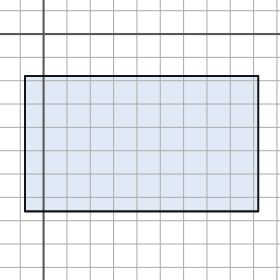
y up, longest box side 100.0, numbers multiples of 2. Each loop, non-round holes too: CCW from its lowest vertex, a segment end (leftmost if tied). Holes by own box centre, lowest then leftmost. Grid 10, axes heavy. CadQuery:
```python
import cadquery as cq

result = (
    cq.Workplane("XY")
    .moveTo(-8.0, -76.0)
    .lineTo(92.0, -76.0)
    .lineTo(92.0, -18.0)
    .lineTo(-8.0, -18.0)
    .close()
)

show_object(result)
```